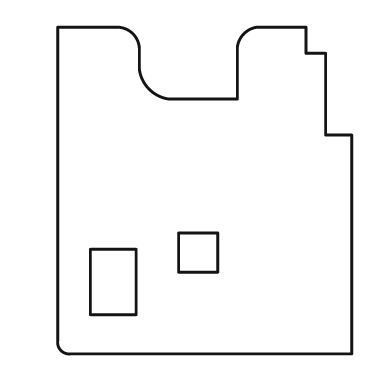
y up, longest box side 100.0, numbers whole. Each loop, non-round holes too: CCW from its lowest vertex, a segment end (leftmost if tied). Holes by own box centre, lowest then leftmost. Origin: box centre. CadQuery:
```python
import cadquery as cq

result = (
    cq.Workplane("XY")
    .moveTo(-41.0, -50.0)
    .lineTo(45.0, -50.0)
    .lineTo(45.0, 17.0)
    .lineTo(37.0, 17.0)
    .lineTo(37.0, 42.0)
    .lineTo(31.0, 42.0)
    .lineTo(31.0, 50.0)
    .lineTo(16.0, 50.0)
    .threePointArc((12.0, 48.0), (10.0, 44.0))
    .lineTo(10.0, 28.0)
    .lineTo(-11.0, 28.0)
    .threePointArc((-17.0, 31.0), (-20.0, 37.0))
    .lineTo(-20.0, 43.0)
    .threePointArc((-22.0, 48.0), (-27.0, 50.0))
    .lineTo(-45.0, 50.0)
    .lineTo(-45.0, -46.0)
    .threePointArc((-44.0, -49.0), (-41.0, -50.0))
    .close()
    .moveTo(-35.0, -38.0)
    .lineTo(-21.0, -38.0)
    .lineTo(-21.0, -18.0)
    .lineTo(-35.0, -18.0)
    .close()
    .moveTo(-8.0, -25.0)
    .lineTo(4.0, -25.0)
    .lineTo(4.0, -13.0)
    .lineTo(-8.0, -13.0)
    .close()
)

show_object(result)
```